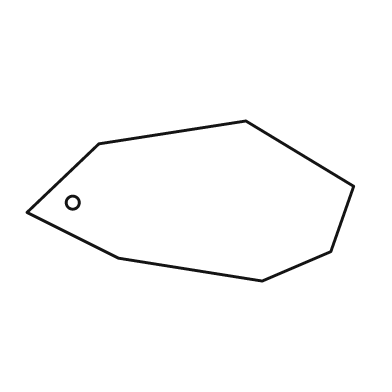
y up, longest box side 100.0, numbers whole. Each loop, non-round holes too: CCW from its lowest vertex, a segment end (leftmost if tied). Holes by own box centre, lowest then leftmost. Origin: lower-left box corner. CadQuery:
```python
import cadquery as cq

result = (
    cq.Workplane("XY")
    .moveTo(72.0, 0.0)
    .lineTo(93.0, 9.0)
    .lineTo(100.0, 29.0)
    .lineTo(67.0, 49.0)
    .lineTo(22.0, 42.0)
    .lineTo(0.0, 21.0)
    .lineTo(28.0, 7.0)
    .close()
    .moveTo(14.0, 24.0)
    .circle(2.0)
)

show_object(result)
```